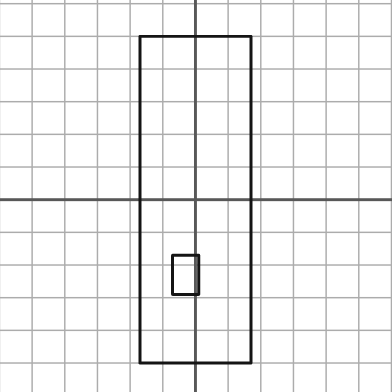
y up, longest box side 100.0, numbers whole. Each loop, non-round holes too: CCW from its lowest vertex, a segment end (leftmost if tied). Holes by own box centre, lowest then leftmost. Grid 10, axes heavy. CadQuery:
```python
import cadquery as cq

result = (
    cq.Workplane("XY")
    .moveTo(-17.0, -50.0)
    .lineTo(17.0, -50.0)
    .lineTo(17.0, 50.0)
    .lineTo(-17.0, 50.0)
    .close()
    .moveTo(-7.0, -29.0)
    .lineTo(1.0, -29.0)
    .lineTo(1.0, -17.0)
    .lineTo(-7.0, -17.0)
    .close()
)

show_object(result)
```